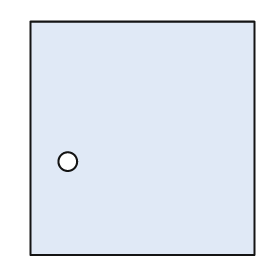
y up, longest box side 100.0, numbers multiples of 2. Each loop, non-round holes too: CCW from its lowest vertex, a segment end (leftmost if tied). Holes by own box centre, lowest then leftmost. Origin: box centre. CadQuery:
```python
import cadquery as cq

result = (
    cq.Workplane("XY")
    .moveTo(-48.0, -50.0)
    .lineTo(48.0, -50.0)
    .lineTo(48.0, 50.0)
    .lineTo(-48.0, 50.0)
    .close()
    .moveTo(-32.0, -10.0)
    .circle(4.0)
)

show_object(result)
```